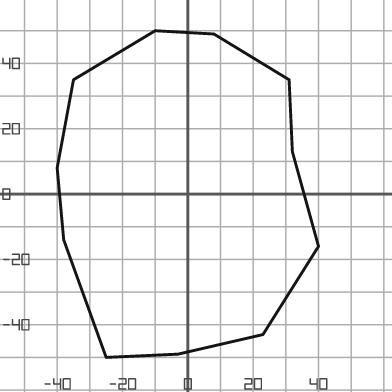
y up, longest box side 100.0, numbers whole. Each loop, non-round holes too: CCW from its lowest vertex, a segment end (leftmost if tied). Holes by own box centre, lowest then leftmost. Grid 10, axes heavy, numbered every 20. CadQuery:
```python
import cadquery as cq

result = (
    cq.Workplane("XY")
    .moveTo(-25.0, -50.0)
    .lineTo(-3.0, -49.0)
    .lineTo(23.0, -43.0)
    .lineTo(40.0, -16.0)
    .lineTo(32.0, 13.0)
    .lineTo(31.0, 35.0)
    .lineTo(8.0, 49.0)
    .lineTo(-10.0, 50.0)
    .lineTo(-35.0, 35.0)
    .lineTo(-40.0, 8.0)
    .lineTo(-38.0, -14.0)
    .close()
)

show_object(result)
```